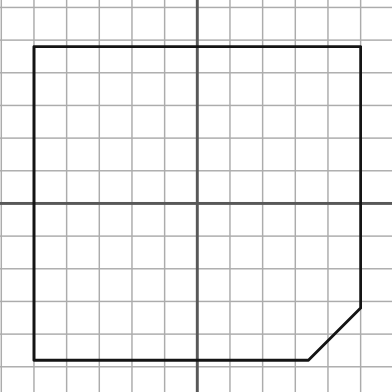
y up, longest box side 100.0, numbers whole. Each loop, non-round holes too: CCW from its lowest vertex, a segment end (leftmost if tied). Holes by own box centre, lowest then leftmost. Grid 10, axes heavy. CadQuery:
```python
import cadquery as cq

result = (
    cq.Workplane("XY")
    .moveTo(-50.0, -48.0)
    .lineTo(34.0, -48.0)
    .lineTo(50.0, -32.0)
    .lineTo(50.0, 48.0)
    .lineTo(-50.0, 48.0)
    .close()
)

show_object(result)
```